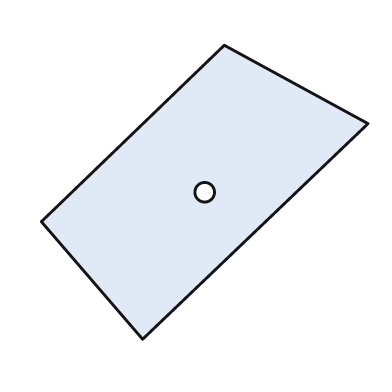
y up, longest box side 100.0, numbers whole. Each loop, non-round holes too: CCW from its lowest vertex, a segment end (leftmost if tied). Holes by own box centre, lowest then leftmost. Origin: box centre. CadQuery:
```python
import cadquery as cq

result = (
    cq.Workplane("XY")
    .moveTo(-19.0, -45.0)
    .lineTo(50.0, 21.0)
    .lineTo(6.0, 45.0)
    .lineTo(-50.0, -9.0)
    .close()
    .moveTo(0.0, 0.0)
    .circle(3.0)
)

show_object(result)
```